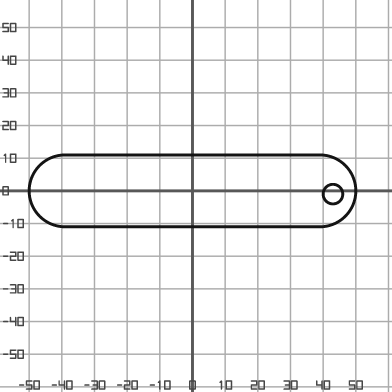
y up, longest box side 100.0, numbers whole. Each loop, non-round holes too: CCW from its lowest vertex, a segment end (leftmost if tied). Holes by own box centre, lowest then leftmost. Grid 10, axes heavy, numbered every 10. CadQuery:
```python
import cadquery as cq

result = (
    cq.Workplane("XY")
    .moveTo(-39.0, -11.0)
    .lineTo(39.0, -11.0)
    .threePointArc((50.0, 0.0), (39.0, 11.0))
    .lineTo(-39.0, 11.0)
    .threePointArc((-50.0, 0.0), (-39.0, -11.0))
    .close()
    .moveTo(43.0, -1.0)
    .circle(3.0)
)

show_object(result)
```